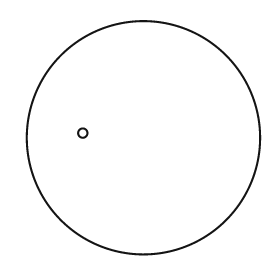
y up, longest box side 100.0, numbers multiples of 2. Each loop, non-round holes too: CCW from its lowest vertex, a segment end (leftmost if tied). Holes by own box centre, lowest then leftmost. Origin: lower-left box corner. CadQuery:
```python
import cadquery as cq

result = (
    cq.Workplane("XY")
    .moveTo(50.0, 50.0)
    .circle(50.0)
    .moveTo(24.0, 52.0)
    .circle(2.0)
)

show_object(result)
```